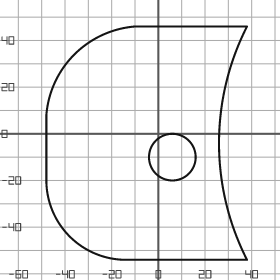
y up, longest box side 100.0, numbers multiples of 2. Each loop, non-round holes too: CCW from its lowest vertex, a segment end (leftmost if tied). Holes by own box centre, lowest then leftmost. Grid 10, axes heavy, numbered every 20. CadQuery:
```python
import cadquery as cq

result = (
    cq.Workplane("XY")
    .moveTo(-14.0, -54.0)
    .lineTo(38.0, -54.0)
    .threePointArc((26.0, -4.0), (38.0, 46.0))
    .lineTo(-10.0, 46.0)
    .threePointArc((-36.0, 34.0), (-48.0, 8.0))
    .lineTo(-48.0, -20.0)
    .threePointArc((-38.0, -44.0), (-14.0, -54.0))
    .close()
    .moveTo(6.0, -10.0)
    .circle(10.0)
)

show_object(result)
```